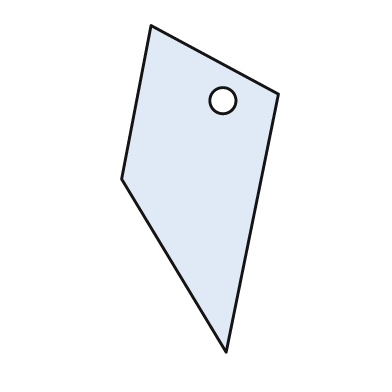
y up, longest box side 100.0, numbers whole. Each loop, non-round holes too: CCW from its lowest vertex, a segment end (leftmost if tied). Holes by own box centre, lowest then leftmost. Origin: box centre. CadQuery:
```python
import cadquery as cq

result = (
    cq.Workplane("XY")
    .moveTo(8.0, -50.0)
    .lineTo(24.0, 29.0)
    .lineTo(-15.0, 50.0)
    .lineTo(-24.0, 3.0)
    .close()
    .moveTo(7.0, 27.0)
    .circle(4.0)
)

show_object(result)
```